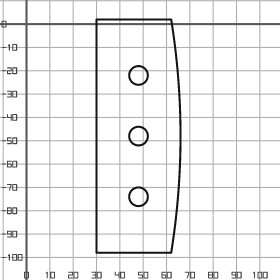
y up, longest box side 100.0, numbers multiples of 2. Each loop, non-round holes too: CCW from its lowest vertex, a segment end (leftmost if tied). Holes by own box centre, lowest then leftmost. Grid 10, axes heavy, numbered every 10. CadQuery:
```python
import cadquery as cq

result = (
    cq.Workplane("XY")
    .moveTo(30.0, -98.0)
    .lineTo(62.0, -98.0)
    .threePointArc((66.0, -48.0), (62.0, 2.0))
    .lineTo(30.0, 2.0)
    .close()
    .moveTo(48.0, -74.0)
    .circle(4.0)
    .moveTo(48.0, -48.0)
    .circle(4.0)
    .moveTo(48.0, -22.0)
    .circle(4.0)
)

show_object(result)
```